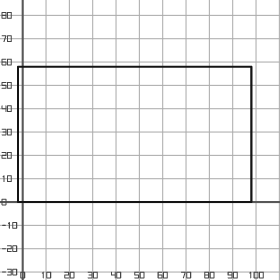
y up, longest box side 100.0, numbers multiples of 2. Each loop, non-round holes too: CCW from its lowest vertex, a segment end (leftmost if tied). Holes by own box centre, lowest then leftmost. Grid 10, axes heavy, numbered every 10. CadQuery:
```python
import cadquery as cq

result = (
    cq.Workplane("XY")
    .moveTo(-2.0, 0.0)
    .lineTo(98.0, 0.0)
    .lineTo(98.0, 58.0)
    .lineTo(-2.0, 58.0)
    .close()
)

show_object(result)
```